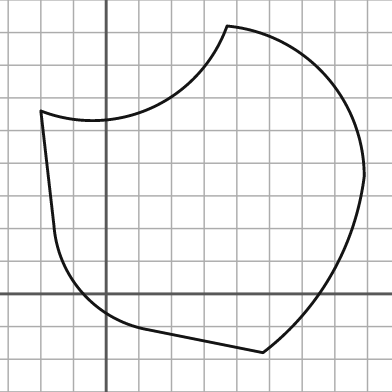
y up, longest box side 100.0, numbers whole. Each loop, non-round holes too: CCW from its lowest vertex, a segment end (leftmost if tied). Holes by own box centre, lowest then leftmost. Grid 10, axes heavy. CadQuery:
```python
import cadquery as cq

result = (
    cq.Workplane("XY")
    .moveTo(48.0, -18.0)
    .threePointArc((69.0, 6.0), (79.0, 36.0))
    .threePointArc((67.0, 67.0), (37.0, 82.0))
    .threePointArc((14.0, 57.0), (-20.0, 56.0))
    .lineTo(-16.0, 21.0)
    .threePointArc((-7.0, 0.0), (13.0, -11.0))
    .close()
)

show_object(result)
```